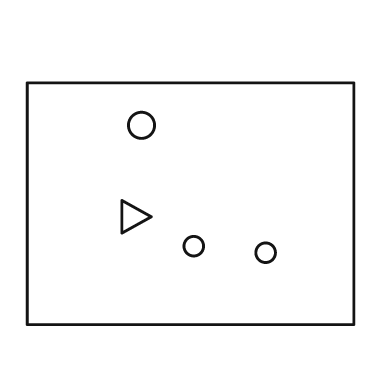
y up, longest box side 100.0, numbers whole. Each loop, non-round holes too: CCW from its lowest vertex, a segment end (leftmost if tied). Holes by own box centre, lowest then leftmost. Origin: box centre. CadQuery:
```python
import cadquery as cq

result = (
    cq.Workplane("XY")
    .moveTo(-50.0, -37.0)
    .lineTo(50.0, -37.0)
    .lineTo(50.0, 37.0)
    .lineTo(-50.0, 37.0)
    .close()
    .moveTo(23.0, -15.0)
    .circle(3.0)
    .moveTo(1.0, -13.0)
    .circle(3.0)
    .moveTo(-21.0, -9.0)
    .lineTo(-12.0, -4.0)
    .lineTo(-21.0, 1.0)
    .close()
    .moveTo(-15.0, 24.0)
    .circle(4.0)
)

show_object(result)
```